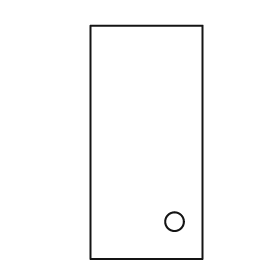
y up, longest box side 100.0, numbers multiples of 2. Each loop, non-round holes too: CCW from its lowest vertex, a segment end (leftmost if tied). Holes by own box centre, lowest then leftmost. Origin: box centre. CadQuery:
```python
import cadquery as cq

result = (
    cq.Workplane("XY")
    .moveTo(-24.0, -50.0)
    .lineTo(24.0, -50.0)
    .lineTo(24.0, 50.0)
    .lineTo(-24.0, 50.0)
    .close()
    .moveTo(12.0, -34.0)
    .circle(4.0)
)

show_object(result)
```